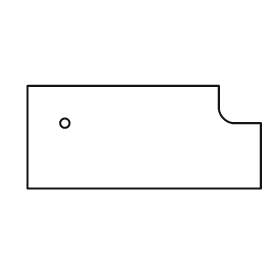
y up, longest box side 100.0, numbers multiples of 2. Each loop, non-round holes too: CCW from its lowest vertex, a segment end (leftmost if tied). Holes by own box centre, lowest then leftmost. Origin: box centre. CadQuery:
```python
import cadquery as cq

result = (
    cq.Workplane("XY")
    .moveTo(-50.0, -22.0)
    .lineTo(50.0, -22.0)
    .lineTo(50.0, 6.0)
    .lineTo(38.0, 6.0)
    .threePointArc((34.0, 8.0), (32.0, 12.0))
    .lineTo(32.0, 22.0)
    .lineTo(-50.0, 22.0)
    .close()
    .moveTo(-34.0, 6.0)
    .circle(2.0)
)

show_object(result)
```